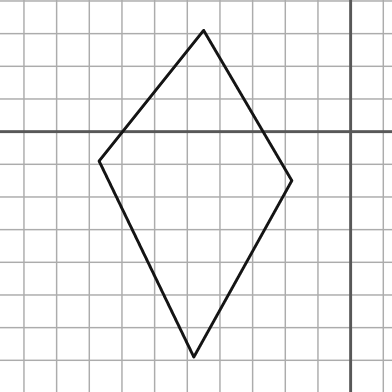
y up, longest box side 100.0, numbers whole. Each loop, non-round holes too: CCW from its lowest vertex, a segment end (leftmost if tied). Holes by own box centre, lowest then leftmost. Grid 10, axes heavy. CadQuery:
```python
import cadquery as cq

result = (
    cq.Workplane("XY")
    .moveTo(-48.0, -69.0)
    .lineTo(-18.0, -15.0)
    .lineTo(-45.0, 31.0)
    .lineTo(-77.0, -9.0)
    .close()
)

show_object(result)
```